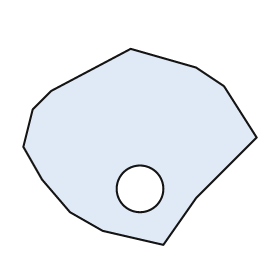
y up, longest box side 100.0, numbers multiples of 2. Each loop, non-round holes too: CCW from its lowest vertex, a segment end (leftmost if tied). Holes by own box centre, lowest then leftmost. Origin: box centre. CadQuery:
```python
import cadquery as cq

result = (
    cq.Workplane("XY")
    .moveTo(10.0, -42.0)
    .lineTo(24.0, -22.0)
    .lineTo(50.0, 4.0)
    .lineTo(36.0, 26.0)
    .lineTo(24.0, 34.0)
    .lineTo(-4.0, 42.0)
    .lineTo(-38.0, 24.0)
    .lineTo(-46.0, 16.0)
    .lineTo(-50.0, 0.0)
    .lineTo(-42.0, -14.0)
    .lineTo(-30.0, -28.0)
    .lineTo(-16.0, -36.0)
    .close()
    .moveTo(0.0, -18.0)
    .circle(10.0)
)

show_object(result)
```